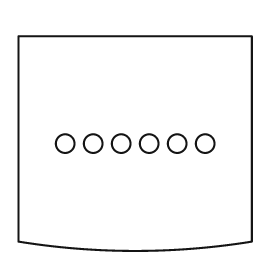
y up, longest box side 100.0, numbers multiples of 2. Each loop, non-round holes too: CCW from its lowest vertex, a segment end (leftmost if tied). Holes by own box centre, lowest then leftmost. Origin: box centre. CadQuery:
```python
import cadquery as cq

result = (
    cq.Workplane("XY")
    .moveTo(-50.0, -42.0)
    .threePointArc((0.0, -46.0), (50.0, -42.0))
    .lineTo(50.0, 46.0)
    .lineTo(-50.0, 46.0)
    .close()
    .moveTo(-30.0, 0.0)
    .circle(4.0)
    .moveTo(-18.0, 0.0)
    .circle(4.0)
    .moveTo(-6.0, 0.0)
    .circle(4.0)
    .moveTo(6.0, 0.0)
    .circle(4.0)
    .moveTo(18.0, 0.0)
    .circle(4.0)
    .moveTo(30.0, 0.0)
    .circle(4.0)
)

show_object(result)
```